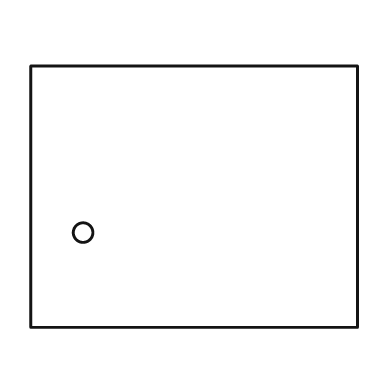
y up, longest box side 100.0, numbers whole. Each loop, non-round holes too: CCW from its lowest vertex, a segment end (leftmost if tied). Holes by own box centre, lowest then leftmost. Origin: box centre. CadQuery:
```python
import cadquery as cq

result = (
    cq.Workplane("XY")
    .moveTo(-50.0, -40.0)
    .lineTo(50.0, -40.0)
    .lineTo(50.0, 40.0)
    .lineTo(-50.0, 40.0)
    .close()
    .moveTo(-34.0, -11.0)
    .circle(3.0)
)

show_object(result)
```